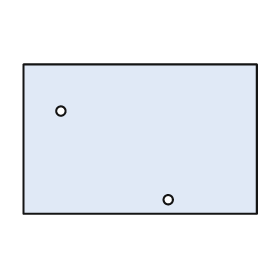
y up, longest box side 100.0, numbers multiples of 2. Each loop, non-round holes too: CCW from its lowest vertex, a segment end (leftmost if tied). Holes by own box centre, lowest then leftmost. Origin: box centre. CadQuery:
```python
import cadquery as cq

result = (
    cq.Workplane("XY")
    .moveTo(-50.0, -32.0)
    .lineTo(50.0, -32.0)
    .lineTo(50.0, 32.0)
    .lineTo(-50.0, 32.0)
    .close()
    .moveTo(12.0, -26.0)
    .circle(2.0)
    .moveTo(-34.0, 12.0)
    .circle(2.0)
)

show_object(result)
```